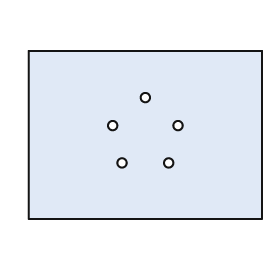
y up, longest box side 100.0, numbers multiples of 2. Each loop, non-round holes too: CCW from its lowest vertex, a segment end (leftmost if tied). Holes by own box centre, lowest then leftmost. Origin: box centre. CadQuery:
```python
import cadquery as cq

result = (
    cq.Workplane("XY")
    .moveTo(-50.0, -36.0)
    .lineTo(50.0, -36.0)
    .lineTo(50.0, 36.0)
    .lineTo(-50.0, 36.0)
    .close()
    .moveTo(-10.0, -12.0)
    .circle(2.0)
    .moveTo(10.0, -12.0)
    .circle(2.0)
    .moveTo(-14.0, 4.0)
    .circle(2.0)
    .moveTo(14.0, 4.0)
    .circle(2.0)
    .moveTo(0.0, 16.0)
    .circle(2.0)
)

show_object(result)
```